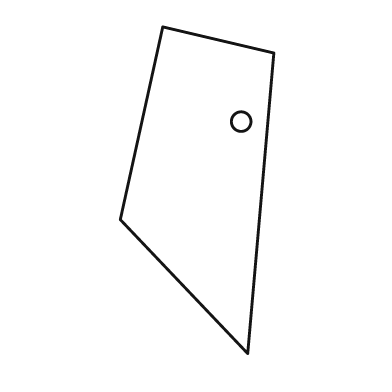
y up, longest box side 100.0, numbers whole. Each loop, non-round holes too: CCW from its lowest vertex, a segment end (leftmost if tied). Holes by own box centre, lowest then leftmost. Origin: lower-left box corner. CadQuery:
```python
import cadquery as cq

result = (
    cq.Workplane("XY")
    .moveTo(39.0, 0.0)
    .lineTo(47.0, 92.0)
    .lineTo(13.0, 100.0)
    .lineTo(0.0, 41.0)
    .close()
    .moveTo(37.0, 71.0)
    .circle(3.0)
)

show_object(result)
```